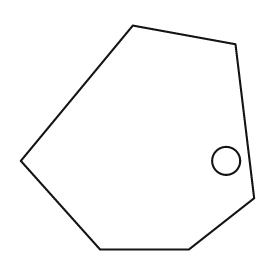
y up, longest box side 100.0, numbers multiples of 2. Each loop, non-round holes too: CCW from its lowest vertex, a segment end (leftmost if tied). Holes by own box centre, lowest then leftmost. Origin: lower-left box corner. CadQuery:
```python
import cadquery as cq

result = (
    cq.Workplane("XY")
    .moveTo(34.0, 0.0)
    .lineTo(72.0, 0.0)
    .lineTo(100.0, 22.0)
    .lineTo(92.0, 88.0)
    .lineTo(48.0, 96.0)
    .lineTo(0.0, 38.0)
    .close()
    .moveTo(88.0, 38.0)
    .circle(6.0)
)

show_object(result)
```